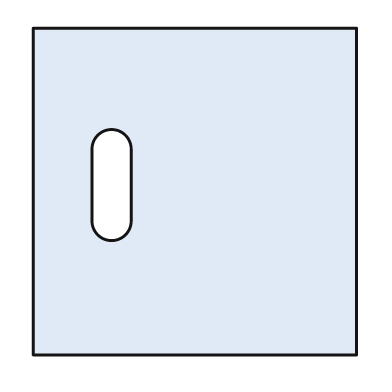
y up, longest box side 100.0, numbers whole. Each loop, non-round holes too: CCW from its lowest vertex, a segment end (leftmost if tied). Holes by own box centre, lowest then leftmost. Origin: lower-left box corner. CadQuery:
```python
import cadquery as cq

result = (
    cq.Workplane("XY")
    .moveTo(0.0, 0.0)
    .lineTo(99.0, 0.0)
    .lineTo(99.0, 100.0)
    .lineTo(0.0, 100.0)
    .close()
    .moveTo(18.0, 41.0)
    .threePointArc((24.0, 35.0), (30.0, 41.0))
    .lineTo(30.0, 63.0)
    .threePointArc((24.0, 69.0), (18.0, 63.0))
    .close()
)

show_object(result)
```